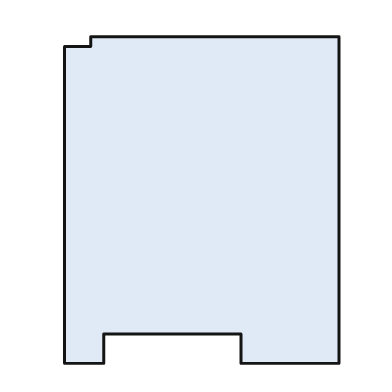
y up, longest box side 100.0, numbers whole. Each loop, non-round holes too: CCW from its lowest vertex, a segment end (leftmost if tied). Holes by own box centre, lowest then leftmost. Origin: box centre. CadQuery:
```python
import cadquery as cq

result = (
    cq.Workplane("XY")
    .moveTo(-42.0, -50.0)
    .lineTo(-30.0, -50.0)
    .lineTo(-30.0, -41.0)
    .lineTo(12.0, -41.0)
    .lineTo(12.0, -50.0)
    .lineTo(42.0, -50.0)
    .lineTo(42.0, 50.0)
    .lineTo(-34.0, 50.0)
    .lineTo(-34.0, 47.0)
    .lineTo(-42.0, 47.0)
    .close()
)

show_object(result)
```